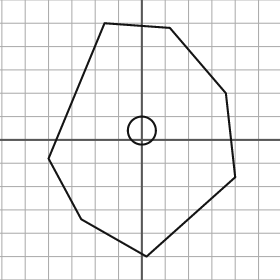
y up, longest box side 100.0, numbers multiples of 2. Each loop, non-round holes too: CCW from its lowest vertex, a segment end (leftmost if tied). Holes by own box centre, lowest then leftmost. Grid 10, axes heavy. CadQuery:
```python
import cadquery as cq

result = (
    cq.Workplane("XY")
    .moveTo(2.0, -50.0)
    .lineTo(40.0, -16.0)
    .lineTo(36.0, 20.0)
    .lineTo(12.0, 48.0)
    .lineTo(-16.0, 50.0)
    .lineTo(-40.0, -8.0)
    .lineTo(-26.0, -34.0)
    .close()
    .moveTo(0.0, 4.0)
    .circle(6.0)
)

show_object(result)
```